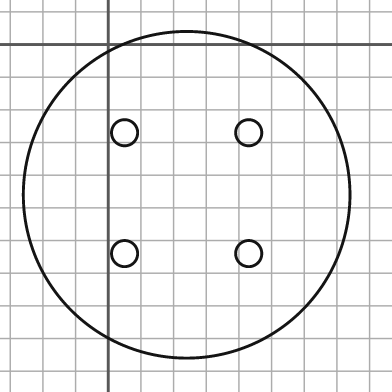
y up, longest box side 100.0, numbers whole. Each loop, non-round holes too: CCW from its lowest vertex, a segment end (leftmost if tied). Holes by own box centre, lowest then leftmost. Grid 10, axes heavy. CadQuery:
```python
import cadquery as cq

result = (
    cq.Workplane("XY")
    .moveTo(24.0, -46.0)
    .circle(50.0)
    .moveTo(5.0, -64.0)
    .circle(4.0)
    .moveTo(43.0, -64.0)
    .circle(4.0)
    .moveTo(5.0, -27.0)
    .circle(4.0)
    .moveTo(43.0, -27.0)
    .circle(4.0)
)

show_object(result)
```